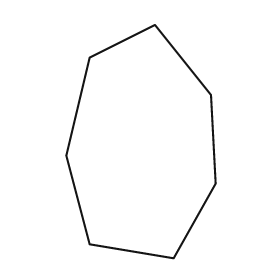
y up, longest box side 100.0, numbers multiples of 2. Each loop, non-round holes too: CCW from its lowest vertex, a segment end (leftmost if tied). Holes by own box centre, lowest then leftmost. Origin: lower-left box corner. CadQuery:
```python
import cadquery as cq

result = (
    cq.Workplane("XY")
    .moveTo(46.0, 0.0)
    .lineTo(64.0, 32.0)
    .lineTo(62.0, 70.0)
    .lineTo(38.0, 100.0)
    .lineTo(10.0, 86.0)
    .lineTo(0.0, 44.0)
    .lineTo(10.0, 6.0)
    .close()
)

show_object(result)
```